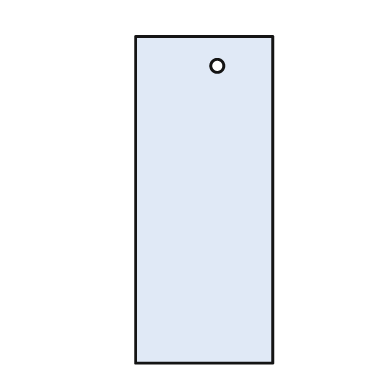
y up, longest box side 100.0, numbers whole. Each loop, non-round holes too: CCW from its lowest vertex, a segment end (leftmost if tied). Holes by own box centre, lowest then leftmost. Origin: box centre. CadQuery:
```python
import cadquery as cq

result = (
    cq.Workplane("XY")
    .moveTo(-21.0, -50.0)
    .lineTo(21.0, -50.0)
    .lineTo(21.0, 50.0)
    .lineTo(-21.0, 50.0)
    .close()
    .moveTo(4.0, 41.0)
    .circle(2.0)
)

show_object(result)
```